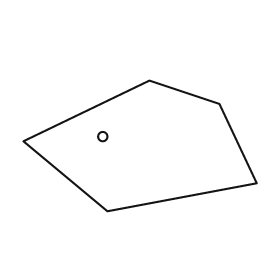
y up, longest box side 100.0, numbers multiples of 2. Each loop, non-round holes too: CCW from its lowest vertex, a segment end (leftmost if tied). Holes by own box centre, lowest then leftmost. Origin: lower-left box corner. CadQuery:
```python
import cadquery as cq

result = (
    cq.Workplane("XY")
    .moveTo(36.0, 0.0)
    .lineTo(100.0, 12.0)
    .lineTo(84.0, 46.0)
    .lineTo(54.0, 56.0)
    .lineTo(0.0, 30.0)
    .close()
    .moveTo(34.0, 32.0)
    .circle(2.0)
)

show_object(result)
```